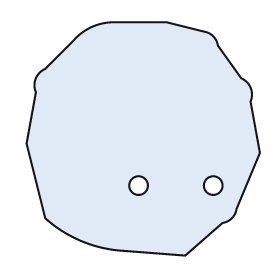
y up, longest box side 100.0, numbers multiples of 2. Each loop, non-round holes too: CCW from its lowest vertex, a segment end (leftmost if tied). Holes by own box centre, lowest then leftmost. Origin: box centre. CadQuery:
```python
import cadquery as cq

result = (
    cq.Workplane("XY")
    .moveTo(18.0, -50.0)
    .lineTo(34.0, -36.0)
    .threePointArc((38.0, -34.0), (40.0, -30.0))
    .lineTo(50.0, -6.0)
    .lineTo(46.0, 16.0)
    .threePointArc((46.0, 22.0), (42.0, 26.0))
    .lineTo(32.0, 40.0)
    .threePointArc((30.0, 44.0), (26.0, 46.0))
    .lineTo(10.0, 50.0)
    .lineTo(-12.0, 50.0)
    .threePointArc((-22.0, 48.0), (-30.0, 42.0))
    .lineTo(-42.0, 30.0)
    .threePointArc((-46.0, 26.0), (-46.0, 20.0))
    .lineTo(-50.0, -2.0)
    .lineTo(-42.0, -34.0)
    .threePointArc((-26.0, -44.0), (-8.0, -48.0))
    .close()
    .moveTo(-2.0, -20.0)
    .circle(4.0)
    .moveTo(30.0, -20.0)
    .circle(4.0)
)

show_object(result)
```